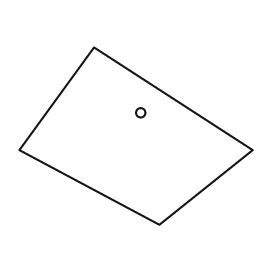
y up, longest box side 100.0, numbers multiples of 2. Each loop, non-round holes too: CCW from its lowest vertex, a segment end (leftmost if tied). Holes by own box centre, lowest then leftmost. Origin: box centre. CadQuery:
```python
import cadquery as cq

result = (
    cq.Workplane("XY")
    .moveTo(10.0, -38.0)
    .lineTo(50.0, -6.0)
    .lineTo(-18.0, 38.0)
    .lineTo(-50.0, -6.0)
    .close()
    .moveTo(2.0, 10.0)
    .circle(2.0)
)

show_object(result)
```